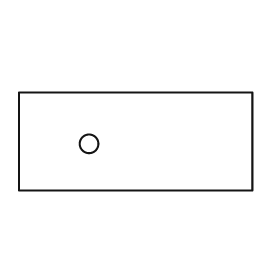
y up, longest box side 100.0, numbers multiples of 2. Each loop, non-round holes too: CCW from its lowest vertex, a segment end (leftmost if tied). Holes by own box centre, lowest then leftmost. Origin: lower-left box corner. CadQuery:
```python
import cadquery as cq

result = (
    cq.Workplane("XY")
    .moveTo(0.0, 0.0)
    .lineTo(100.0, 0.0)
    .lineTo(100.0, 42.0)
    .lineTo(0.0, 42.0)
    .close()
    .moveTo(30.0, 20.0)
    .circle(4.0)
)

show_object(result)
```